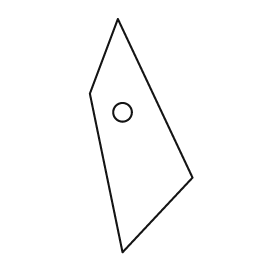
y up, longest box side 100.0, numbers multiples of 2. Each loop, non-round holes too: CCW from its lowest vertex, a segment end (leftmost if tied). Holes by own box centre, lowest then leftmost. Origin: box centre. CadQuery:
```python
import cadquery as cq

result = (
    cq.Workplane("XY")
    .moveTo(-8.0, -50.0)
    .lineTo(22.0, -18.0)
    .lineTo(-10.0, 50.0)
    .lineTo(-22.0, 18.0)
    .close()
    .moveTo(-8.0, 10.0)
    .circle(4.0)
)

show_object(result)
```